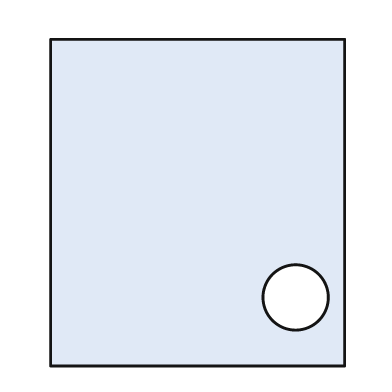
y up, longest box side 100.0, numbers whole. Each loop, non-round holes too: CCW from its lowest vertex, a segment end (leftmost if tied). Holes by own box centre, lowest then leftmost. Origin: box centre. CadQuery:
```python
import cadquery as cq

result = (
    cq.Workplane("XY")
    .moveTo(-45.0, -50.0)
    .lineTo(45.0, -50.0)
    .lineTo(45.0, 50.0)
    .lineTo(-45.0, 50.0)
    .close()
    .moveTo(30.0, -29.0)
    .circle(10.0)
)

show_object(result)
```